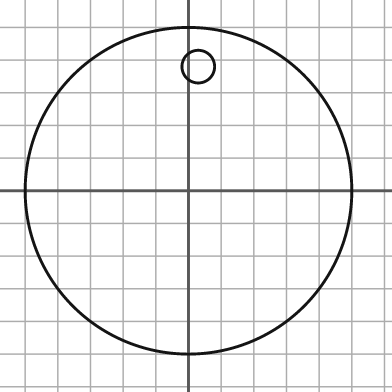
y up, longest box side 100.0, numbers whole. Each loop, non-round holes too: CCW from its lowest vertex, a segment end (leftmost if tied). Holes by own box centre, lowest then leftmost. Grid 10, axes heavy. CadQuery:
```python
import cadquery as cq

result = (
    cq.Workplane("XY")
    .moveTo(0.0, 0.0)
    .circle(50.0)
    .moveTo(3.0, 38.0)
    .circle(5.0)
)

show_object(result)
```